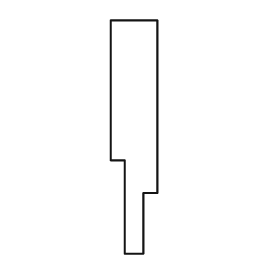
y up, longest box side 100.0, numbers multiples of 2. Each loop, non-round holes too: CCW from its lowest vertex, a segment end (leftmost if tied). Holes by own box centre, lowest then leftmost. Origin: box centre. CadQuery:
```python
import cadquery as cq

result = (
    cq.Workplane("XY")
    .moveTo(-4.0, -50.0)
    .lineTo(4.0, -50.0)
    .lineTo(4.0, -24.0)
    .lineTo(10.0, -24.0)
    .lineTo(10.0, 50.0)
    .lineTo(-10.0, 50.0)
    .lineTo(-10.0, -10.0)
    .lineTo(-4.0, -10.0)
    .close()
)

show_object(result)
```